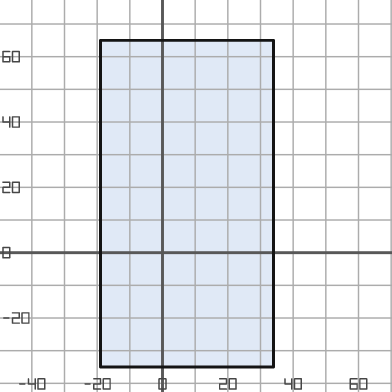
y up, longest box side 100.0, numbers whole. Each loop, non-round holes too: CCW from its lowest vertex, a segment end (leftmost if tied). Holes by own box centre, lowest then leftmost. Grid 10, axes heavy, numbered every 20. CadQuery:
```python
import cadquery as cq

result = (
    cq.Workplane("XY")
    .moveTo(-19.0, -35.0)
    .lineTo(34.0, -35.0)
    .lineTo(34.0, 65.0)
    .lineTo(-19.0, 65.0)
    .close()
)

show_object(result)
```